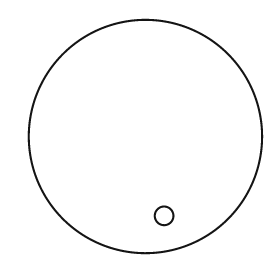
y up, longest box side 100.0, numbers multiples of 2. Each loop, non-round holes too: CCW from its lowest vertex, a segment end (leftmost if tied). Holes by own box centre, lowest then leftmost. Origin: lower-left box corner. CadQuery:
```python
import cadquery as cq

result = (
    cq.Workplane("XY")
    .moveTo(50.0, 50.0)
    .circle(50.0)
    .moveTo(58.0, 16.0)
    .circle(4.0)
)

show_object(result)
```